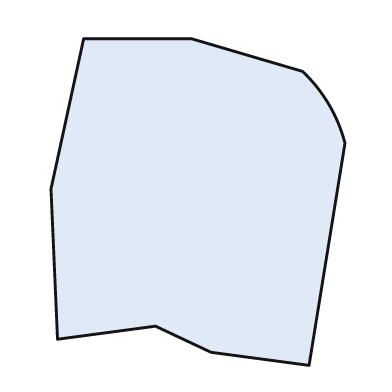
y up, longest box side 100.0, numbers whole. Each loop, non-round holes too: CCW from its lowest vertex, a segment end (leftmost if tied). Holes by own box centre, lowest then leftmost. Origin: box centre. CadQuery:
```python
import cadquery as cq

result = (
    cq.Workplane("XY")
    .moveTo(34.0, -50.0)
    .lineTo(45.0, 18.0)
    .threePointArc((40.0, 30.0), (32.0, 40.0))
    .lineTo(-2.0, 50.0)
    .lineTo(-35.0, 50.0)
    .lineTo(-45.0, 4.0)
    .lineTo(-43.0, -42.0)
    .lineTo(-13.0, -38.0)
    .lineTo(4.0, -46.0)
    .close()
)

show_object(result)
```